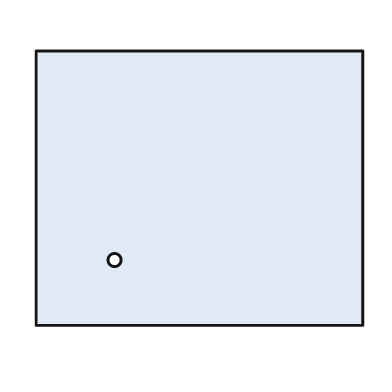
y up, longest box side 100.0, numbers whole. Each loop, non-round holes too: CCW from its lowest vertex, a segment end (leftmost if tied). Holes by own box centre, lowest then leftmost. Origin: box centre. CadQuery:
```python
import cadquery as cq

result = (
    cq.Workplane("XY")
    .moveTo(-50.0, -42.0)
    .lineTo(50.0, -42.0)
    .lineTo(50.0, 42.0)
    .lineTo(-50.0, 42.0)
    .close()
    .moveTo(-26.0, -22.0)
    .circle(2.0)
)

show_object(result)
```